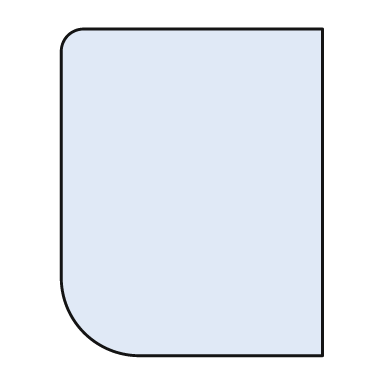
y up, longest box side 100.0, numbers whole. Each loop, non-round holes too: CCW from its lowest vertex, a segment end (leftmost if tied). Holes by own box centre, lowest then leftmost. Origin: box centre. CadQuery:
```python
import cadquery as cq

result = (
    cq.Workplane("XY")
    .moveTo(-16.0, -50.0)
    .lineTo(40.0, -50.0)
    .lineTo(40.0, 50.0)
    .lineTo(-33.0, 50.0)
    .threePointArc((-38.0, 48.0), (-40.0, 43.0))
    .lineTo(-40.0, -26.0)
    .threePointArc((-33.0, -43.0), (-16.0, -50.0))
    .close()
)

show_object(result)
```